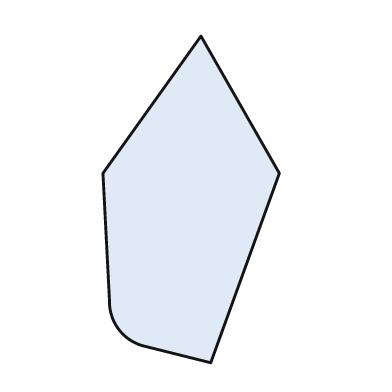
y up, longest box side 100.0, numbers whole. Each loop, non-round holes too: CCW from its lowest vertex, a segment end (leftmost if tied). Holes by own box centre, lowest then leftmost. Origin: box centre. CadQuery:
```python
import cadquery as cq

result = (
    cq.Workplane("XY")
    .moveTo(6.0, -50.0)
    .lineTo(27.0, 8.0)
    .lineTo(3.0, 50.0)
    .lineTo(-27.0, 8.0)
    .lineTo(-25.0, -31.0)
    .threePointArc((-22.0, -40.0), (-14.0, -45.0))
    .close()
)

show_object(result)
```